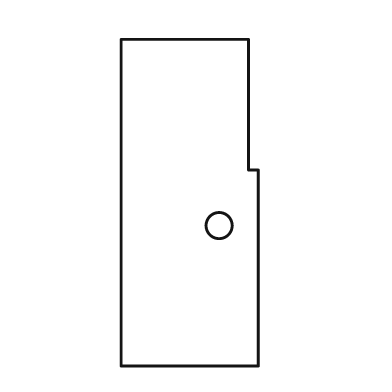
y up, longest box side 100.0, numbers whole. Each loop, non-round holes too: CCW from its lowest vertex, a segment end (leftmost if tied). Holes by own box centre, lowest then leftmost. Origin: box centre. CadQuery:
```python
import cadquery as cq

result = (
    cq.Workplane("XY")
    .moveTo(-21.0, -50.0)
    .lineTo(21.0, -50.0)
    .lineTo(21.0, 10.0)
    .lineTo(18.0, 10.0)
    .lineTo(18.0, 50.0)
    .lineTo(-21.0, 50.0)
    .close()
    .moveTo(9.0, -7.0)
    .circle(4.0)
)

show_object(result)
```